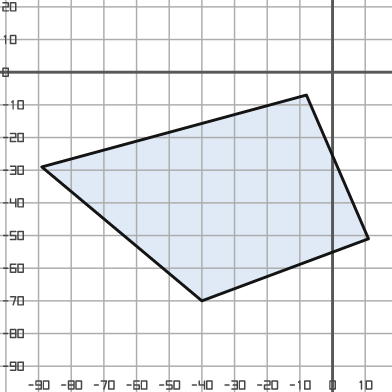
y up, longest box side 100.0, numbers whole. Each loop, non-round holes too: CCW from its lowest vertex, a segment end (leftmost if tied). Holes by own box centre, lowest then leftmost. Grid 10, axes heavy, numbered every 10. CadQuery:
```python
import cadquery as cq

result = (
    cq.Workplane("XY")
    .moveTo(-40.0, -70.0)
    .lineTo(11.0, -51.0)
    .lineTo(-8.0, -7.0)
    .lineTo(-89.0, -29.0)
    .close()
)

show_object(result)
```